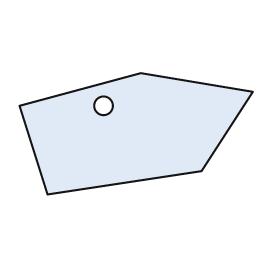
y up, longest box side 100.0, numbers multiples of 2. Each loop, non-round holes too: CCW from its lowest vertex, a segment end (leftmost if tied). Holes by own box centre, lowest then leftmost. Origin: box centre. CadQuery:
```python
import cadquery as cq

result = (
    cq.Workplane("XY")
    .moveTo(-38.0, -26.0)
    .lineTo(28.0, -16.0)
    .lineTo(50.0, 18.0)
    .lineTo(2.0, 26.0)
    .lineTo(-50.0, 12.0)
    .close()
    .moveTo(-14.0, 12.0)
    .circle(4.0)
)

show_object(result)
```